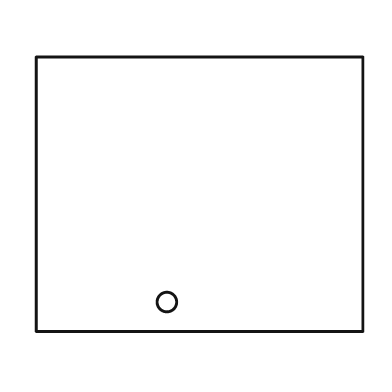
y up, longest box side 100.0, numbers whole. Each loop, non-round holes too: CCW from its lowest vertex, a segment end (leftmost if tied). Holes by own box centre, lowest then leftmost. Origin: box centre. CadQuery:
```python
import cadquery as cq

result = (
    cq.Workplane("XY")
    .moveTo(-50.0, -42.0)
    .lineTo(50.0, -42.0)
    .lineTo(50.0, 42.0)
    .lineTo(-50.0, 42.0)
    .close()
    .moveTo(-10.0, -33.0)
    .circle(3.0)
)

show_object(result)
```